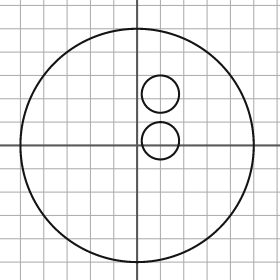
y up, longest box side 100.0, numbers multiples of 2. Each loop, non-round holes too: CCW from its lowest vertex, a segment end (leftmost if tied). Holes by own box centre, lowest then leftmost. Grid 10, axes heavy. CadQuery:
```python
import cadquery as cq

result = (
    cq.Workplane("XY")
    .moveTo(0.0, 0.0)
    .circle(50.0)
    .moveTo(10.0, 2.0)
    .circle(8.0)
    .moveTo(10.0, 22.0)
    .circle(8.0)
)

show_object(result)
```